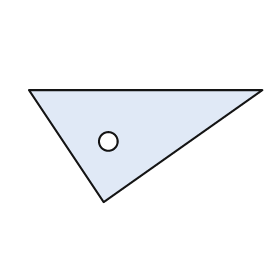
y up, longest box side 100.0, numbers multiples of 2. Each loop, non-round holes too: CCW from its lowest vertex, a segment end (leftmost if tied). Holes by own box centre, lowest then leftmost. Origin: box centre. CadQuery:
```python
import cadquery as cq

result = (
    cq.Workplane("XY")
    .moveTo(-18.0, -24.0)
    .lineTo(50.0, 24.0)
    .lineTo(-50.0, 24.0)
    .close()
    .moveTo(-16.0, 2.0)
    .circle(4.0)
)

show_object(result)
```